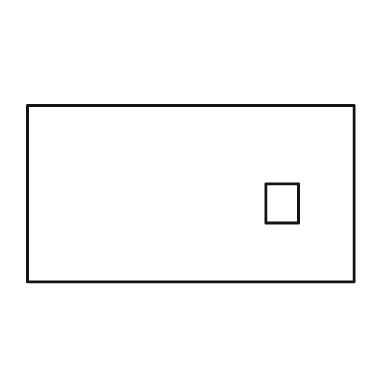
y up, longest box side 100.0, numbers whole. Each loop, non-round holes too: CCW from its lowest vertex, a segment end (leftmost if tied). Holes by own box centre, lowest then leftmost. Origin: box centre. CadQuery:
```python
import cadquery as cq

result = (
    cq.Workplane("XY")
    .moveTo(-50.0, -27.0)
    .lineTo(50.0, -27.0)
    .lineTo(50.0, 27.0)
    .lineTo(-50.0, 27.0)
    .close()
    .moveTo(23.0, -9.0)
    .lineTo(33.0, -9.0)
    .lineTo(33.0, 3.0)
    .lineTo(23.0, 3.0)
    .close()
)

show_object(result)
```